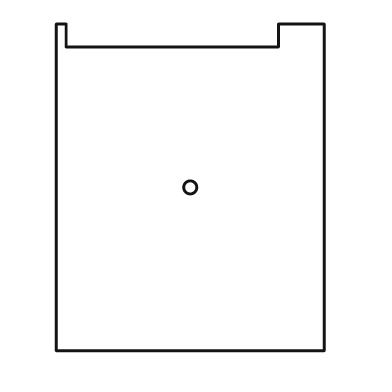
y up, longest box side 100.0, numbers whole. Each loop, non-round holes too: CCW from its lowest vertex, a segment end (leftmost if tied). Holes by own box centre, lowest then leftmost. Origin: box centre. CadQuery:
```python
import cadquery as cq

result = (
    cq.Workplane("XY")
    .moveTo(-41.0, -50.0)
    .lineTo(41.0, -50.0)
    .lineTo(41.0, 50.0)
    .lineTo(27.0, 50.0)
    .lineTo(27.0, 43.0)
    .lineTo(-38.0, 43.0)
    .lineTo(-38.0, 50.0)
    .lineTo(-41.0, 50.0)
    .close()
    .moveTo(0.0, 0.0)
    .circle(2.0)
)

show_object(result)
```